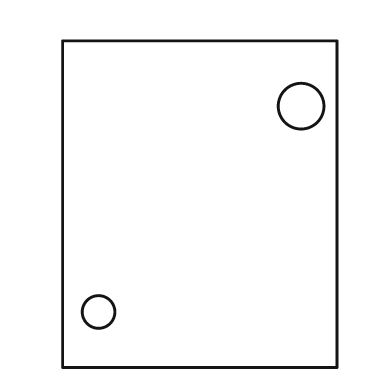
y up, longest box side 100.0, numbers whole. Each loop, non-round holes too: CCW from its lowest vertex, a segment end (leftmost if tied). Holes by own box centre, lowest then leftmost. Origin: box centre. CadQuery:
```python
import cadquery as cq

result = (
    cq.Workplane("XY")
    .moveTo(-42.0, -50.0)
    .lineTo(42.0, -50.0)
    .lineTo(42.0, 50.0)
    .lineTo(-42.0, 50.0)
    .close()
    .moveTo(-31.0, -33.0)
    .circle(5.0)
    .moveTo(31.0, 30.0)
    .circle(7.0)
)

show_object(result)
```